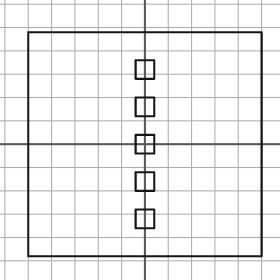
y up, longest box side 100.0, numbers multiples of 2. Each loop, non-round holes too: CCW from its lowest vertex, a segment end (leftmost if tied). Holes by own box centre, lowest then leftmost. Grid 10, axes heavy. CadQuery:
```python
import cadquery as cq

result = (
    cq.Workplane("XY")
    .moveTo(-50.0, -48.0)
    .lineTo(50.0, -48.0)
    .lineTo(50.0, 48.0)
    .lineTo(-50.0, 48.0)
    .close()
    .moveTo(-4.0, -36.0)
    .lineTo(4.0, -36.0)
    .lineTo(4.0, -28.0)
    .lineTo(-4.0, -28.0)
    .close()
    .moveTo(-4.0, -20.0)
    .lineTo(4.0, -20.0)
    .lineTo(4.0, -12.0)
    .lineTo(-4.0, -12.0)
    .close()
    .moveTo(-4.0, -4.0)
    .lineTo(4.0, -4.0)
    .lineTo(4.0, 4.0)
    .lineTo(-4.0, 4.0)
    .close()
    .moveTo(-4.0, 12.0)
    .lineTo(4.0, 12.0)
    .lineTo(4.0, 20.0)
    .lineTo(-4.0, 20.0)
    .close()
    .moveTo(-4.0, 28.0)
    .lineTo(4.0, 28.0)
    .lineTo(4.0, 36.0)
    .lineTo(-4.0, 36.0)
    .close()
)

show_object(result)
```